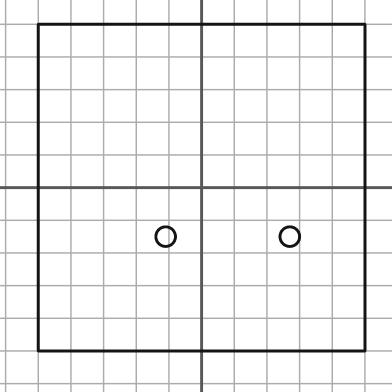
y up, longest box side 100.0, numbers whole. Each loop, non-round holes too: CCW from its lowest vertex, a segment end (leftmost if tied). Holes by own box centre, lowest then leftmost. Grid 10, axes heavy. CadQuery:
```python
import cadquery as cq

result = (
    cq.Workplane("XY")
    .moveTo(-50.0, -50.0)
    .lineTo(50.0, -50.0)
    .lineTo(50.0, 50.0)
    .lineTo(-50.0, 50.0)
    .close()
    .moveTo(-11.0, -15.0)
    .circle(3.0)
    .moveTo(27.0, -15.0)
    .circle(3.0)
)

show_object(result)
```